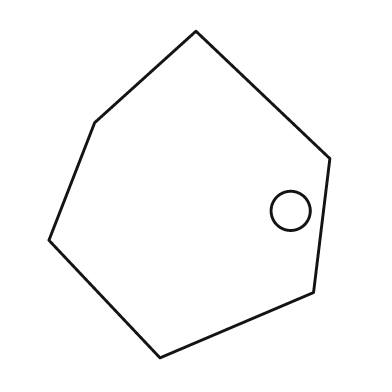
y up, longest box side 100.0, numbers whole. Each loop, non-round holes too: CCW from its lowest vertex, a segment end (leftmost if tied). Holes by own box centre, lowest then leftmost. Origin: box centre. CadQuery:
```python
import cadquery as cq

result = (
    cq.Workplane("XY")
    .moveTo(-9.0, -50.0)
    .lineTo(38.0, -30.0)
    .lineTo(43.0, 11.0)
    .lineTo(2.0, 50.0)
    .lineTo(-29.0, 22.0)
    .lineTo(-43.0, -14.0)
    .close()
    .moveTo(31.0, -5.0)
    .circle(6.0)
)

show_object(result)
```